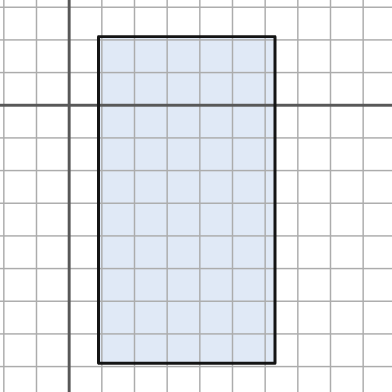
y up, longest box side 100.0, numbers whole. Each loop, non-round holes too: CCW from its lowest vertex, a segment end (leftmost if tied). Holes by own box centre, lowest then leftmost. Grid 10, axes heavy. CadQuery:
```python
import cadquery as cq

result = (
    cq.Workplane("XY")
    .moveTo(9.0, -79.0)
    .lineTo(63.0, -79.0)
    .lineTo(63.0, 21.0)
    .lineTo(9.0, 21.0)
    .close()
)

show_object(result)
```